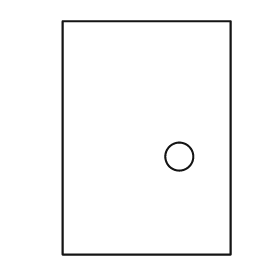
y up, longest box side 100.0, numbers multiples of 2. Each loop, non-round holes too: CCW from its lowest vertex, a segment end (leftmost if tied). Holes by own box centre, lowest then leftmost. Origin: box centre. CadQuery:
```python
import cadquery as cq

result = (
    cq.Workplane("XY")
    .moveTo(-36.0, -50.0)
    .lineTo(36.0, -50.0)
    .lineTo(36.0, 50.0)
    .lineTo(-36.0, 50.0)
    .close()
    .moveTo(14.0, -8.0)
    .circle(6.0)
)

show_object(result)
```